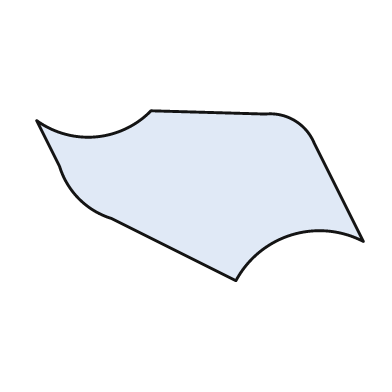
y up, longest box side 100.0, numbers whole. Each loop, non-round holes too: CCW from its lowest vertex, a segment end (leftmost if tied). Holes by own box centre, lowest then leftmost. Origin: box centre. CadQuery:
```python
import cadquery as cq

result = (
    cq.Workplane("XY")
    .moveTo(11.0, -26.0)
    .threePointArc((28.0, -12.0), (50.0, -14.0))
    .lineTo(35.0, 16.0)
    .threePointArc((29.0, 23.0), (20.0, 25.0))
    .lineTo(-15.0, 26.0)
    .threePointArc((-32.0, 18.0), (-50.0, 23.0))
    .lineTo(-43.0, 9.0)
    .threePointArc((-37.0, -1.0), (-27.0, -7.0))
    .close()
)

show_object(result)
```